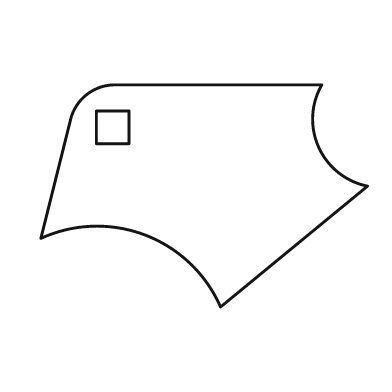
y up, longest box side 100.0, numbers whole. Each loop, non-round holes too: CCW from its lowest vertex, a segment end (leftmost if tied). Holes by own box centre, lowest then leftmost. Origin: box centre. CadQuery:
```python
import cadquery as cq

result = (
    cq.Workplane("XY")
    .moveTo(5.0, -34.0)
    .lineTo(50.0, 3.0)
    .threePointArc((35.0, 15.0), (36.0, 34.0))
    .lineTo(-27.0, 34.0)
    .threePointArc((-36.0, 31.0), (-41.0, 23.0))
    .lineTo(-50.0, -13.0)
    .threePointArc((-18.0, -12.0), (5.0, -34.0))
    .close()
    .moveTo(-33.0, 16.0)
    .lineTo(-23.0, 16.0)
    .lineTo(-23.0, 26.0)
    .lineTo(-33.0, 26.0)
    .close()
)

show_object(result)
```